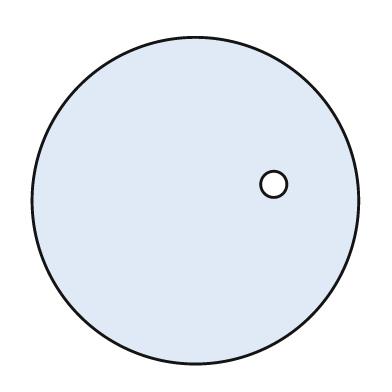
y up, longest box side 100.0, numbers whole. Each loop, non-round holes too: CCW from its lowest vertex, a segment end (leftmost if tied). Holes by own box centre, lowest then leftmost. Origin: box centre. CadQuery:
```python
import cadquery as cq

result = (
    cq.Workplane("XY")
    .moveTo(0.0, 0.0)
    .circle(50.0)
    .moveTo(24.0, 5.0)
    .circle(4.0)
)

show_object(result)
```